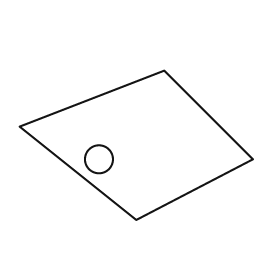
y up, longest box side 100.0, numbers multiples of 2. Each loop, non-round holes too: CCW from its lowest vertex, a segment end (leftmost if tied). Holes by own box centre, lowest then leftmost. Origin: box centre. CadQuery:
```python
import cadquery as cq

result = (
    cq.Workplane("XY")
    .moveTo(0.0, -32.0)
    .lineTo(50.0, -6.0)
    .lineTo(12.0, 32.0)
    .lineTo(-50.0, 8.0)
    .close()
    .moveTo(-16.0, -6.0)
    .circle(6.0)
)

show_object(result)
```